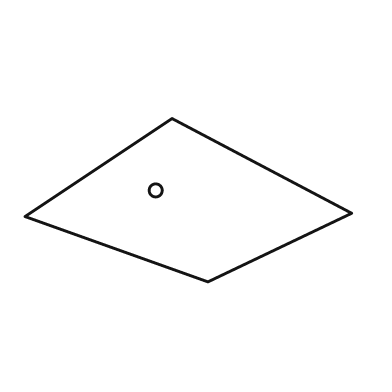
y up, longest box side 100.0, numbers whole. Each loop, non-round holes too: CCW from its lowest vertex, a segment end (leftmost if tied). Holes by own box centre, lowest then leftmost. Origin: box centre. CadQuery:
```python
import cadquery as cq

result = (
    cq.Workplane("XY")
    .moveTo(6.0, -25.0)
    .lineTo(50.0, -4.0)
    .lineTo(-5.0, 25.0)
    .lineTo(-50.0, -5.0)
    .close()
    .moveTo(-10.0, 3.0)
    .circle(2.0)
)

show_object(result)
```